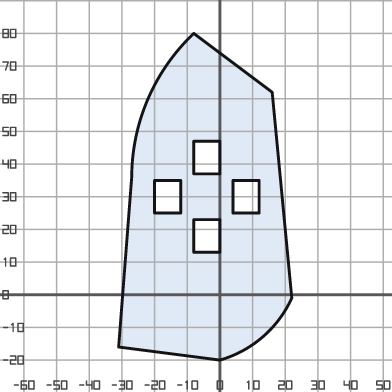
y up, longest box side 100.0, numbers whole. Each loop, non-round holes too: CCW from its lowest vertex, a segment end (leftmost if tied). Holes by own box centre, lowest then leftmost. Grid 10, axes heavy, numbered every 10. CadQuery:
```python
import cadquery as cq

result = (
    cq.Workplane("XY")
    .moveTo(0.0, -20.0)
    .threePointArc((13.0, -13.0), (22.0, -1.0))
    .lineTo(16.0, 62.0)
    .lineTo(-8.0, 80.0)
    .threePointArc((-22.0, 60.0), (-27.0, 36.0))
    .lineTo(-31.0, -16.0)
    .close()
    .moveTo(-8.0, 13.0)
    .lineTo(0.0, 13.0)
    .lineTo(0.0, 23.0)
    .lineTo(-8.0, 23.0)
    .close()
    .moveTo(-20.0, 25.0)
    .lineTo(-12.0, 25.0)
    .lineTo(-12.0, 35.0)
    .lineTo(-20.0, 35.0)
    .close()
    .moveTo(4.0, 25.0)
    .lineTo(12.0, 25.0)
    .lineTo(12.0, 35.0)
    .lineTo(4.0, 35.0)
    .close()
    .moveTo(-8.0, 37.0)
    .lineTo(0.0, 37.0)
    .lineTo(0.0, 47.0)
    .lineTo(-8.0, 47.0)
    .close()
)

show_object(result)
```